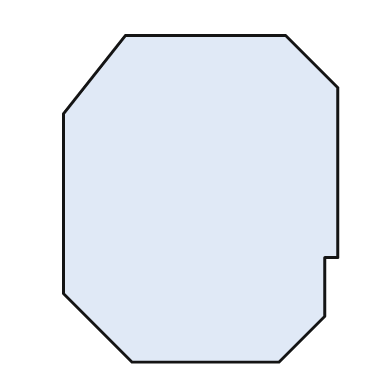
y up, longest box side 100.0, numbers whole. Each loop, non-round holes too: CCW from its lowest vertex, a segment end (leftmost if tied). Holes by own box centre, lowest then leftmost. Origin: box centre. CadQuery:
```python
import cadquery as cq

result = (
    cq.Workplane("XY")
    .moveTo(-21.0, -50.0)
    .lineTo(24.0, -50.0)
    .lineTo(38.0, -36.0)
    .lineTo(38.0, -18.0)
    .lineTo(42.0, -18.0)
    .lineTo(42.0, 34.0)
    .lineTo(26.0, 50.0)
    .lineTo(-23.0, 50.0)
    .lineTo(-42.0, 26.0)
    .lineTo(-42.0, -29.0)
    .close()
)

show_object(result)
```